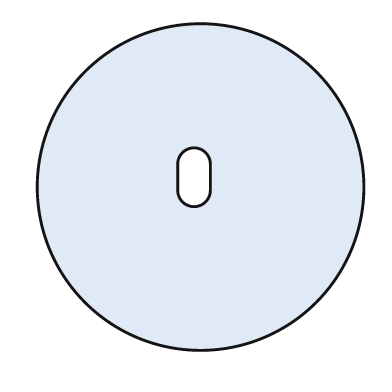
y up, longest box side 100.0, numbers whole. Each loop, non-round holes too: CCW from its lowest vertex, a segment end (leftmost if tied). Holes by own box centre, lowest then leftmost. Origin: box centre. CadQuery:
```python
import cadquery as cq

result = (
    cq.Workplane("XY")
    .moveTo(0.0, 0.0)
    .circle(50.0)
    .moveTo(-7.0, -1.0)
    .threePointArc((-2.0, -6.0), (3.0, -1.0))
    .lineTo(3.0, 7.0)
    .threePointArc((-2.0, 12.0), (-7.0, 7.0))
    .close()
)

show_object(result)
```